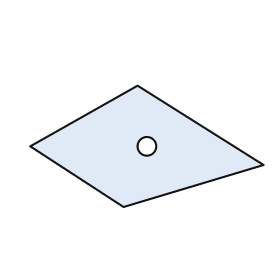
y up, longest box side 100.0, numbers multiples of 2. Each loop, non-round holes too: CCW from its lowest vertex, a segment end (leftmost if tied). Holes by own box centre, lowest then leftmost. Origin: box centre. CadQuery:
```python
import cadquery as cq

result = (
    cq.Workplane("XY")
    .moveTo(-10.0, -26.0)
    .lineTo(50.0, -8.0)
    .lineTo(-4.0, 26.0)
    .lineTo(-50.0, 0.0)
    .close()
    .moveTo(0.0, 0.0)
    .circle(4.0)
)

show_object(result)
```